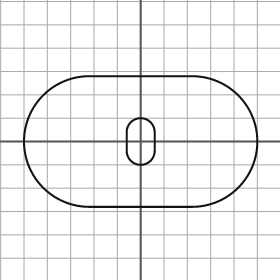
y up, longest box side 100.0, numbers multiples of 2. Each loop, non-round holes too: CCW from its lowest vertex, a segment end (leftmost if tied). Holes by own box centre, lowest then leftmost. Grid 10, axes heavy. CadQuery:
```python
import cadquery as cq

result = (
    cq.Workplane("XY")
    .moveTo(-22.0, -28.0)
    .lineTo(22.0, -28.0)
    .threePointArc((50.0, 0.0), (22.0, 28.0))
    .lineTo(-22.0, 28.0)
    .threePointArc((-50.0, 0.0), (-22.0, -28.0))
    .close()
    .moveTo(-6.0, -4.0)
    .threePointArc((0.0, -10.0), (6.0, -4.0))
    .lineTo(6.0, 4.0)
    .threePointArc((0.0, 10.0), (-6.0, 4.0))
    .close()
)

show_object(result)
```